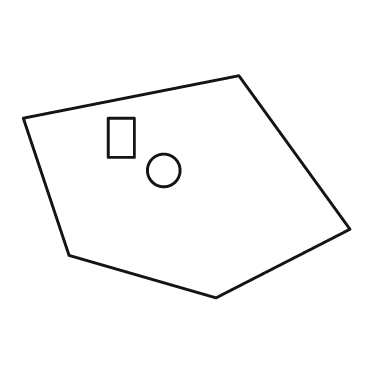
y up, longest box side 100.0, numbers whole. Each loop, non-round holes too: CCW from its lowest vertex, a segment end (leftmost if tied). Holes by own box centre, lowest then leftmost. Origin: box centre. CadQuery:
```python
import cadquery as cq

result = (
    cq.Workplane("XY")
    .moveTo(9.0, -34.0)
    .lineTo(50.0, -13.0)
    .lineTo(16.0, 34.0)
    .lineTo(-50.0, 21.0)
    .lineTo(-36.0, -21.0)
    .close()
    .moveTo(-7.0, 5.0)
    .circle(5.0)
    .moveTo(-24.0, 9.0)
    .lineTo(-16.0, 9.0)
    .lineTo(-16.0, 21.0)
    .lineTo(-24.0, 21.0)
    .close()
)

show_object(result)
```